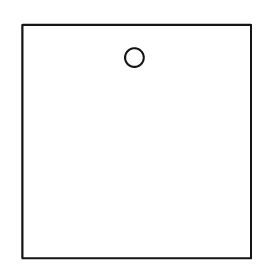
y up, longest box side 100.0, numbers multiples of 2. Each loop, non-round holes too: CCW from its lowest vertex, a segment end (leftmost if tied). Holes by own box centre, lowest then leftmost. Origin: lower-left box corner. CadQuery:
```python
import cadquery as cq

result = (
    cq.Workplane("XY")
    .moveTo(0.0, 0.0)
    .lineTo(98.0, 0.0)
    .lineTo(98.0, 100.0)
    .lineTo(0.0, 100.0)
    .close()
    .moveTo(48.0, 86.0)
    .circle(4.0)
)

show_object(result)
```